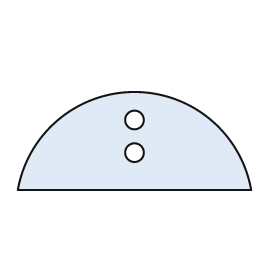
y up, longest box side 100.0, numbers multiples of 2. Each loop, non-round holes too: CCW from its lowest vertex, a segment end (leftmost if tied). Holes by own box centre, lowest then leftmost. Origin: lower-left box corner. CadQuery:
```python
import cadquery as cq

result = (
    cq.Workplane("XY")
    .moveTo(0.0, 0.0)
    .lineTo(100.0, 0.0)
    .threePointArc((50.0, 42.0), (0.0, 0.0))
    .close()
    .moveTo(50.0, 16.0)
    .circle(4.0)
    .moveTo(50.0, 30.0)
    .circle(4.0)
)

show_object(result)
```